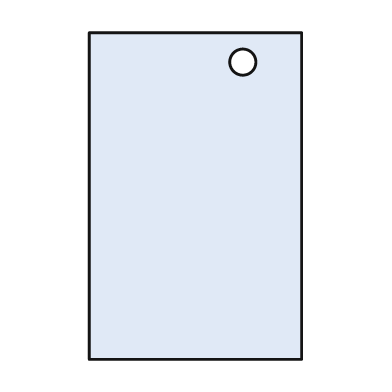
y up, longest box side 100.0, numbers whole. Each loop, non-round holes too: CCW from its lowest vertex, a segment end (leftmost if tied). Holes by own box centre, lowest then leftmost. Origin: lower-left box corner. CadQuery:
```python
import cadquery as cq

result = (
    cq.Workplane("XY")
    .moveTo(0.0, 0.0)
    .lineTo(65.0, 0.0)
    .lineTo(65.0, 100.0)
    .lineTo(0.0, 100.0)
    .close()
    .moveTo(47.0, 91.0)
    .circle(4.0)
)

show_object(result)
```